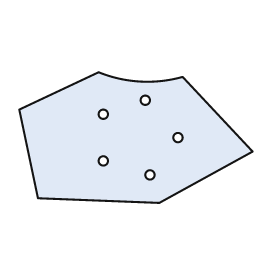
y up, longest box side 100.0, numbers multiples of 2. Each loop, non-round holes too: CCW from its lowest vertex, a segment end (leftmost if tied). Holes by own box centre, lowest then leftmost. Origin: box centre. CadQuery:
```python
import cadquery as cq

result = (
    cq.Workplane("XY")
    .moveTo(10.0, -28.0)
    .lineTo(50.0, -6.0)
    .lineTo(20.0, 26.0)
    .threePointArc((2.0, 24.0), (-16.0, 28.0))
    .lineTo(-50.0, 12.0)
    .lineTo(-42.0, -26.0)
    .close()
    .moveTo(6.0, -16.0)
    .circle(2.0)
    .moveTo(-14.0, -10.0)
    .circle(2.0)
    .moveTo(18.0, 0.0)
    .circle(2.0)
    .moveTo(-14.0, 10.0)
    .circle(2.0)
    .moveTo(4.0, 16.0)
    .circle(2.0)
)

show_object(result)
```